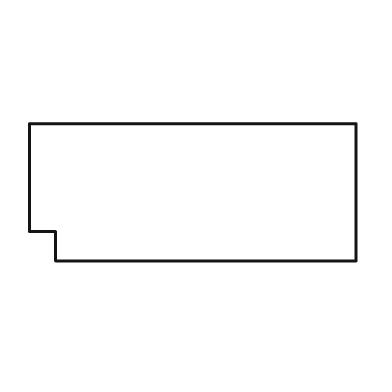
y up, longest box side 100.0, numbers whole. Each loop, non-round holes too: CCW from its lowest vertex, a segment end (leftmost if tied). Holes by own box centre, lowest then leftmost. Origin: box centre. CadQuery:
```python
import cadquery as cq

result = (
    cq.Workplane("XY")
    .moveTo(-42.0, -21.0)
    .lineTo(50.0, -21.0)
    .lineTo(50.0, 21.0)
    .lineTo(-50.0, 21.0)
    .lineTo(-50.0, -12.0)
    .lineTo(-42.0, -12.0)
    .close()
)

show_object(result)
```